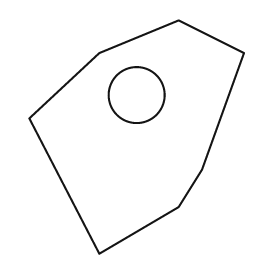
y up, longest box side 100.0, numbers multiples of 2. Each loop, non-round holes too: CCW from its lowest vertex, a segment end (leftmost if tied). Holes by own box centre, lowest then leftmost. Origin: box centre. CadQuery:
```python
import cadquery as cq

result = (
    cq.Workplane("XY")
    .moveTo(-16.0, -50.0)
    .lineTo(18.0, -30.0)
    .lineTo(28.0, -14.0)
    .lineTo(46.0, 36.0)
    .lineTo(18.0, 50.0)
    .lineTo(-16.0, 36.0)
    .lineTo(-46.0, 8.0)
    .close()
    .moveTo(0.0, 18.0)
    .circle(12.0)
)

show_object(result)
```